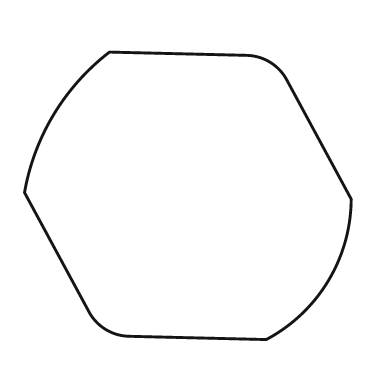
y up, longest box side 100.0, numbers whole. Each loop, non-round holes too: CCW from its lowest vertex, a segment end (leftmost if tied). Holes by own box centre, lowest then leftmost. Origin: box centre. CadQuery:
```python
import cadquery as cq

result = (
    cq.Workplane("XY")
    .moveTo(24.0, -44.0)
    .threePointArc((43.0, -26.0), (50.0, -1.0))
    .lineTo(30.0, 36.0)
    .threePointArc((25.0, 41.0), (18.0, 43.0))
    .lineTo(-24.0, 44.0)
    .threePointArc((-41.0, 25.0), (-50.0, 1.0))
    .lineTo(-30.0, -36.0)
    .threePointArc((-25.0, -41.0), (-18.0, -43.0))
    .close()
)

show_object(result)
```